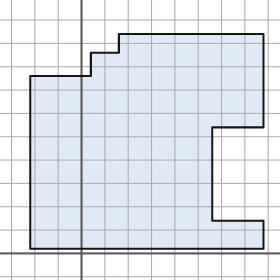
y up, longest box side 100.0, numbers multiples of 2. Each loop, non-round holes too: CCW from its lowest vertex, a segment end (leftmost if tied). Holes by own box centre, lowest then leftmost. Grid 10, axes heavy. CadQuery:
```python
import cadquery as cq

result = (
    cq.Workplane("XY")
    .moveTo(-22.0, 2.0)
    .lineTo(78.0, 2.0)
    .lineTo(78.0, 14.0)
    .lineTo(56.0, 14.0)
    .lineTo(56.0, 54.0)
    .lineTo(78.0, 54.0)
    .lineTo(78.0, 94.0)
    .lineTo(16.0, 94.0)
    .lineTo(16.0, 86.0)
    .lineTo(4.0, 86.0)
    .lineTo(4.0, 76.0)
    .lineTo(-22.0, 76.0)
    .close()
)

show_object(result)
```